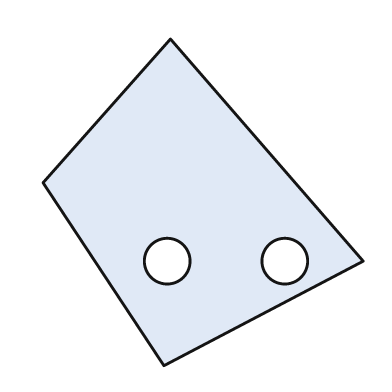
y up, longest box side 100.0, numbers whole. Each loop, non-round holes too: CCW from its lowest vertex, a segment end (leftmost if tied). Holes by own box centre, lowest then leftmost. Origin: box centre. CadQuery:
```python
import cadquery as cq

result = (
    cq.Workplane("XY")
    .moveTo(-12.0, -50.0)
    .lineTo(49.0, -18.0)
    .lineTo(-10.0, 50.0)
    .lineTo(-49.0, 6.0)
    .close()
    .moveTo(-11.0, -18.0)
    .circle(7.0)
    .moveTo(25.0, -18.0)
    .circle(7.0)
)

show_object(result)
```